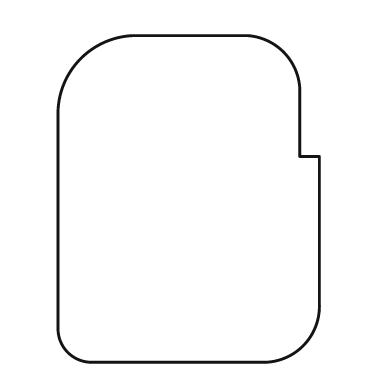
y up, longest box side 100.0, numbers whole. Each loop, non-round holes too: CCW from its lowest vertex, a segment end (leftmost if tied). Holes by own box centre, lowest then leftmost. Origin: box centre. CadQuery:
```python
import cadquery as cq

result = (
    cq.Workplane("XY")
    .moveTo(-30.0, -50.0)
    .lineTo(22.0, -50.0)
    .threePointArc((35.0, -45.0), (40.0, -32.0))
    .lineTo(40.0, 13.0)
    .lineTo(34.0, 13.0)
    .lineTo(34.0, 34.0)
    .threePointArc((29.0, 45.0), (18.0, 50.0))
    .lineTo(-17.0, 50.0)
    .threePointArc((-33.0, 43.0), (-40.0, 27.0))
    .lineTo(-40.0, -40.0)
    .threePointArc((-37.0, -47.0), (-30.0, -50.0))
    .close()
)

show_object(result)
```